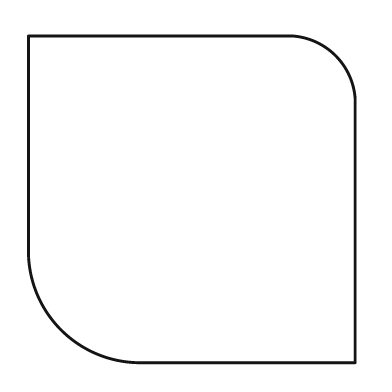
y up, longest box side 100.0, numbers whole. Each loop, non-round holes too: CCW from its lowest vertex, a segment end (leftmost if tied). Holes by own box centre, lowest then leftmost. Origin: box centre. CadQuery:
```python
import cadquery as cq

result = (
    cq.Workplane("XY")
    .moveTo(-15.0, -50.0)
    .lineTo(50.0, -50.0)
    .lineTo(50.0, 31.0)
    .threePointArc((44.0, 44.0), (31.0, 50.0))
    .lineTo(-50.0, 50.0)
    .lineTo(-50.0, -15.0)
    .threePointArc((-40.0, -40.0), (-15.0, -50.0))
    .close()
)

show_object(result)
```